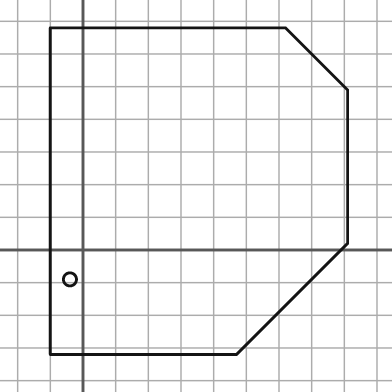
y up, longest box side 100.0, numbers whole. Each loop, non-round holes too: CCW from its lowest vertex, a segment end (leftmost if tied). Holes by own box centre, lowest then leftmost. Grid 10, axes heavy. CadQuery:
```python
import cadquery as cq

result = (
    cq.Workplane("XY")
    .moveTo(-10.0, -32.0)
    .lineTo(47.0, -32.0)
    .lineTo(81.0, 2.0)
    .lineTo(81.0, 49.0)
    .lineTo(62.0, 68.0)
    .lineTo(-10.0, 68.0)
    .close()
    .moveTo(-4.0, -9.0)
    .circle(2.0)
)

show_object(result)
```